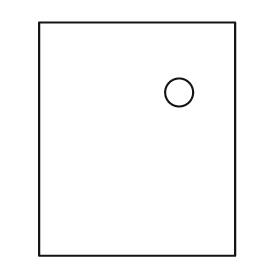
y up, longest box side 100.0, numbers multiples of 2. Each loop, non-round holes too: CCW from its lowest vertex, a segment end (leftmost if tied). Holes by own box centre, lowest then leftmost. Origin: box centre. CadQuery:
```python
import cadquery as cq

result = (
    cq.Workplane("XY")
    .moveTo(-42.0, -50.0)
    .lineTo(42.0, -50.0)
    .lineTo(42.0, 50.0)
    .lineTo(-42.0, 50.0)
    .close()
    .moveTo(18.0, 20.0)
    .circle(6.0)
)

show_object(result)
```